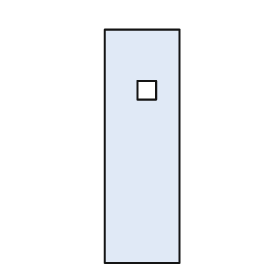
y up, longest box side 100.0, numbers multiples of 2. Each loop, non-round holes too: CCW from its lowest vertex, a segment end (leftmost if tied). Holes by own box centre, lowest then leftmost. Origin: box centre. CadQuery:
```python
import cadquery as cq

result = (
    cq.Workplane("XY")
    .moveTo(-16.0, -50.0)
    .lineTo(16.0, -50.0)
    .lineTo(16.0, 50.0)
    .lineTo(-16.0, 50.0)
    .close()
    .moveTo(-2.0, 20.0)
    .lineTo(6.0, 20.0)
    .lineTo(6.0, 28.0)
    .lineTo(-2.0, 28.0)
    .close()
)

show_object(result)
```